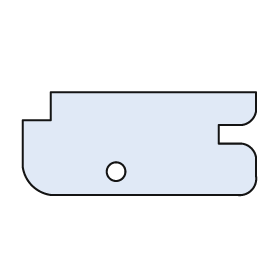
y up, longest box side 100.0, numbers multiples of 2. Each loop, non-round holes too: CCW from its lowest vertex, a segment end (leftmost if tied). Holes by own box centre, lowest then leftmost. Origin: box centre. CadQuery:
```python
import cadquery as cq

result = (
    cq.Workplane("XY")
    .moveTo(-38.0, -22.0)
    .lineTo(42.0, -22.0)
    .threePointArc((48.0, -20.0), (50.0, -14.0))
    .lineTo(50.0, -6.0)
    .threePointArc((48.0, -2.0), (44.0, 0.0))
    .lineTo(34.0, 0.0)
    .lineTo(34.0, 8.0)
    .lineTo(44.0, 8.0)
    .threePointArc((48.0, 10.0), (50.0, 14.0))
    .lineTo(50.0, 22.0)
    .lineTo(-38.0, 22.0)
    .lineTo(-38.0, 10.0)
    .lineTo(-50.0, 10.0)
    .lineTo(-50.0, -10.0)
    .threePointArc((-46.0, -18.0), (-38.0, -22.0))
    .close()
    .moveTo(-10.0, -12.0)
    .circle(4.0)
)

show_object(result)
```